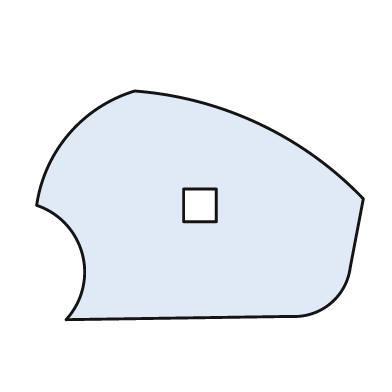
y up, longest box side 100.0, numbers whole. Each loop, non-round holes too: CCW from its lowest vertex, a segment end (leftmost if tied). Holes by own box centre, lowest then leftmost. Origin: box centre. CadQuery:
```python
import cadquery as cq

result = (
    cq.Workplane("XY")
    .moveTo(-41.0, -35.0)
    .lineTo(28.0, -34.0)
    .threePointArc((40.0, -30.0), (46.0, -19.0))
    .lineTo(50.0, 2.0)
    .threePointArc((18.0, 25.0), (-20.0, 35.0))
    .threePointArc((-40.0, 22.0), (-50.0, 0.0))
    .threePointArc((-36.0, -15.0), (-41.0, -35.0))
    .close()
    .moveTo(-5.0, -5.0)
    .lineTo(5.0, -5.0)
    .lineTo(5.0, 5.0)
    .lineTo(-5.0, 5.0)
    .close()
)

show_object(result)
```